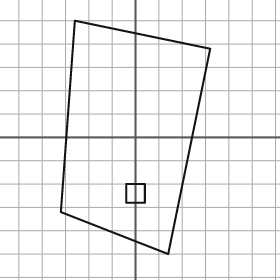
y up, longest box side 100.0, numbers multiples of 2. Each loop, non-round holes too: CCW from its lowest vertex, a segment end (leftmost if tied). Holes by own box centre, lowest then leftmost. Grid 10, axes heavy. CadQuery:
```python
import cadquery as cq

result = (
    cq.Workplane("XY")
    .moveTo(14.0, -50.0)
    .lineTo(32.0, 38.0)
    .lineTo(-26.0, 50.0)
    .lineTo(-32.0, -32.0)
    .close()
    .moveTo(-4.0, -28.0)
    .lineTo(4.0, -28.0)
    .lineTo(4.0, -20.0)
    .lineTo(-4.0, -20.0)
    .close()
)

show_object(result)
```